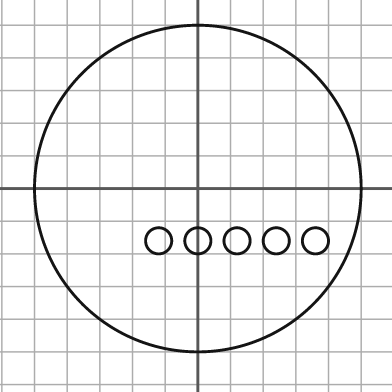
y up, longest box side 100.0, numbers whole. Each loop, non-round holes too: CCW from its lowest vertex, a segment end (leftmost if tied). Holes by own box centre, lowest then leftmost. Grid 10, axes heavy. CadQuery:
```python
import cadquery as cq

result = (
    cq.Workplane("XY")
    .moveTo(0.0, 0.0)
    .circle(50.0)
    .moveTo(-12.0, -16.0)
    .circle(4.0)
    .moveTo(0.0, -16.0)
    .circle(4.0)
    .moveTo(12.0, -16.0)
    .circle(4.0)
    .moveTo(24.0, -16.0)
    .circle(4.0)
    .moveTo(36.0, -16.0)
    .circle(4.0)
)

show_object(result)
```